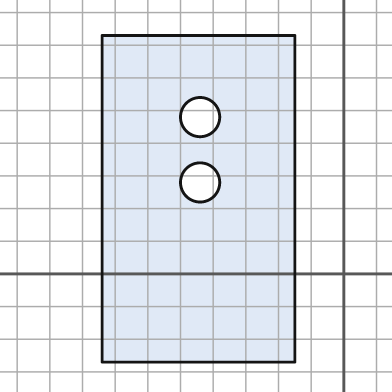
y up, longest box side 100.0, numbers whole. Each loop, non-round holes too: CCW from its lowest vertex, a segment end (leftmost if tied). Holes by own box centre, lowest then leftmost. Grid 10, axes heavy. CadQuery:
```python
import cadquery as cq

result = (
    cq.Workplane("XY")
    .moveTo(-74.0, -27.0)
    .lineTo(-15.0, -27.0)
    .lineTo(-15.0, 73.0)
    .lineTo(-74.0, 73.0)
    .close()
    .moveTo(-44.0, 28.0)
    .circle(6.0)
    .moveTo(-44.0, 48.0)
    .circle(6.0)
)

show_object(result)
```